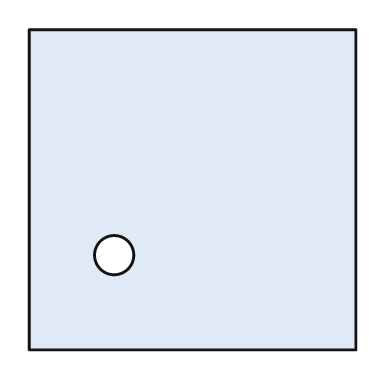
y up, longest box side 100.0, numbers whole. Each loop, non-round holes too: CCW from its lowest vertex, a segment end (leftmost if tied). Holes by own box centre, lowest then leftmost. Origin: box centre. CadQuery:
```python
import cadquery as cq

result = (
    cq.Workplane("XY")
    .moveTo(-50.0, -49.0)
    .lineTo(50.0, -49.0)
    .lineTo(50.0, 49.0)
    .lineTo(-50.0, 49.0)
    .close()
    .moveTo(-24.0, -20.0)
    .circle(6.0)
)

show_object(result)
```